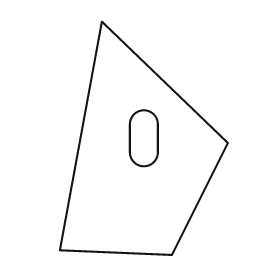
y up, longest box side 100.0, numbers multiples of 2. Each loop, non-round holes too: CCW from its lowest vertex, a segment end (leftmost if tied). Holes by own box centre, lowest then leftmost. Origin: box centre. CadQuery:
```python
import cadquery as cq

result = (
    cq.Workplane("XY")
    .moveTo(12.0, -50.0)
    .lineTo(36.0, -2.0)
    .lineTo(-18.0, 50.0)
    .lineTo(-36.0, -48.0)
    .close()
    .moveTo(-6.0, -6.0)
    .threePointArc((0.0, -12.0), (6.0, -6.0))
    .lineTo(6.0, 6.0)
    .threePointArc((0.0, 12.0), (-6.0, 6.0))
    .close()
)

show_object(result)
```